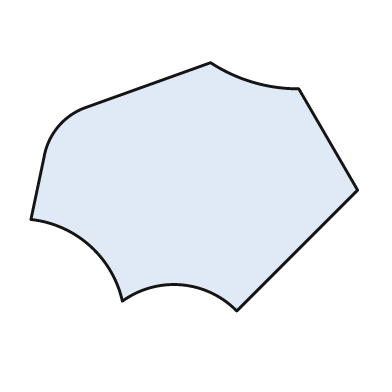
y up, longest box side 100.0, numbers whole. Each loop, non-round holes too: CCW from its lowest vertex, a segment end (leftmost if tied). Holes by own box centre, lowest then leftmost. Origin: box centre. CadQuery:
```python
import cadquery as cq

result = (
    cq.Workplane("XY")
    .moveTo(13.0, -38.0)
    .lineTo(50.0, -1.0)
    .lineTo(32.0, 30.0)
    .threePointArc((18.0, 32.0), (5.0, 38.0))
    .lineTo(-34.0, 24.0)
    .threePointArc((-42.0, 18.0), (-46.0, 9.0))
    .lineTo(-50.0, -10.0)
    .threePointArc((-32.0, -18.0), (-22.0, -35.0))
    .threePointArc((-4.0, -30.0), (13.0, -38.0))
    .close()
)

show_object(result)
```